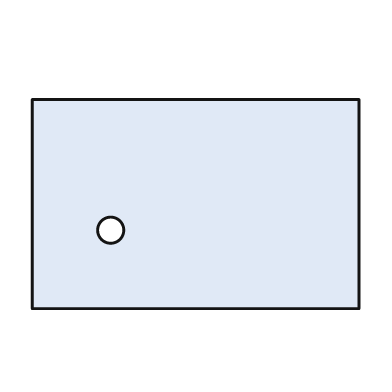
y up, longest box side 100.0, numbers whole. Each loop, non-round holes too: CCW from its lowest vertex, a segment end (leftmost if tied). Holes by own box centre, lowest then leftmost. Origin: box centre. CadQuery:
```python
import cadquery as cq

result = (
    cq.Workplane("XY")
    .moveTo(-50.0, -32.0)
    .lineTo(50.0, -32.0)
    .lineTo(50.0, 32.0)
    .lineTo(-50.0, 32.0)
    .close()
    .moveTo(-26.0, -8.0)
    .circle(4.0)
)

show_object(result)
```